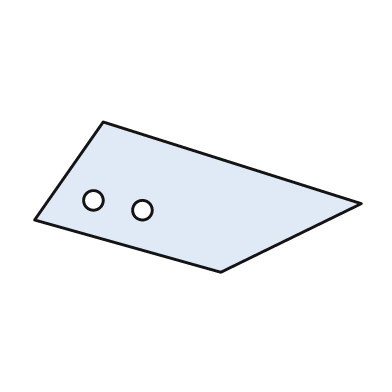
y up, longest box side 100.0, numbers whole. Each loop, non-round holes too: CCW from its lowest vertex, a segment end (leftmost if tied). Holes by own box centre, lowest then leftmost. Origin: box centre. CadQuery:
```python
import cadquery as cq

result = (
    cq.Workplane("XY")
    .moveTo(7.0, -23.0)
    .lineTo(50.0, -2.0)
    .lineTo(-29.0, 23.0)
    .lineTo(-50.0, -7.0)
    .close()
    .moveTo(-17.0, -4.0)
    .circle(3.0)
    .moveTo(-32.0, -1.0)
    .circle(3.0)
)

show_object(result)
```